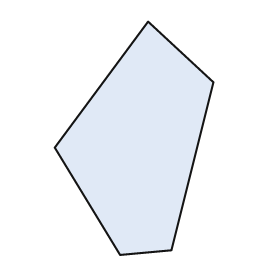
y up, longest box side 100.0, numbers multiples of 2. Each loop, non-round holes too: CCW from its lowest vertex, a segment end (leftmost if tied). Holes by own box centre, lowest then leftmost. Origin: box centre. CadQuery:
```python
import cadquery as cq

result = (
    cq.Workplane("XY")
    .moveTo(-6.0, -50.0)
    .lineTo(16.0, -48.0)
    .lineTo(34.0, 24.0)
    .lineTo(6.0, 50.0)
    .lineTo(-34.0, -4.0)
    .close()
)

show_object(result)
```